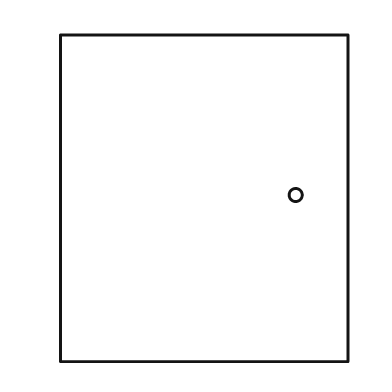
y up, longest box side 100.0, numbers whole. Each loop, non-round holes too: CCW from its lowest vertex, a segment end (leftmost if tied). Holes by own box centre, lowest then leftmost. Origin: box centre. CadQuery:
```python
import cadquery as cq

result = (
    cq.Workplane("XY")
    .moveTo(-44.0, -50.0)
    .lineTo(44.0, -50.0)
    .lineTo(44.0, 50.0)
    .lineTo(-44.0, 50.0)
    .close()
    .moveTo(28.0, 1.0)
    .circle(2.0)
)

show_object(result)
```